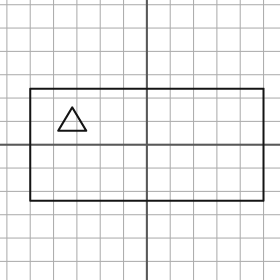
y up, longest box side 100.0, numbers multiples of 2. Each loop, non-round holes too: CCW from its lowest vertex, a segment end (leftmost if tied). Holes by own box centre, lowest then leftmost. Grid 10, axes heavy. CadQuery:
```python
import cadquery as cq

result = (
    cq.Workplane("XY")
    .moveTo(-50.0, -24.0)
    .lineTo(50.0, -24.0)
    .lineTo(50.0, 24.0)
    .lineTo(-50.0, 24.0)
    .close()
    .moveTo(-38.0, 6.0)
    .lineTo(-26.0, 6.0)
    .lineTo(-32.0, 16.0)
    .close()
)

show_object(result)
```